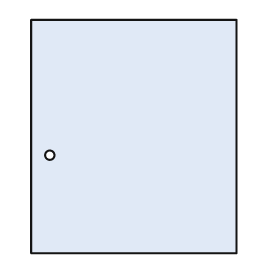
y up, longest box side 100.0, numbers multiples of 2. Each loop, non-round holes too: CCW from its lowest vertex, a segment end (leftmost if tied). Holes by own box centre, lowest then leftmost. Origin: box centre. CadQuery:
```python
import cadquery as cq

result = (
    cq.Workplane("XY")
    .moveTo(-44.0, -50.0)
    .lineTo(44.0, -50.0)
    .lineTo(44.0, 50.0)
    .lineTo(-44.0, 50.0)
    .close()
    .moveTo(-36.0, -8.0)
    .circle(2.0)
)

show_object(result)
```